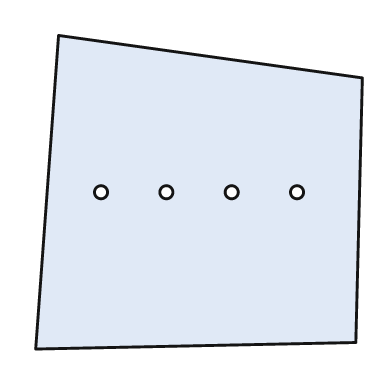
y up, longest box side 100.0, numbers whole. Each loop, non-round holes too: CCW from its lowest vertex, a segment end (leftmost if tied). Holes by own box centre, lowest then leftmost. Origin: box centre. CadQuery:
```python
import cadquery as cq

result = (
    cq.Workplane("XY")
    .moveTo(-50.0, -48.0)
    .lineTo(48.0, -46.0)
    .lineTo(50.0, 35.0)
    .lineTo(-43.0, 48.0)
    .close()
    .moveTo(-30.0, 0.0)
    .circle(2.0)
    .moveTo(-10.0, 0.0)
    .circle(2.0)
    .moveTo(10.0, 0.0)
    .circle(2.0)
    .moveTo(30.0, 0.0)
    .circle(2.0)
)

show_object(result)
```